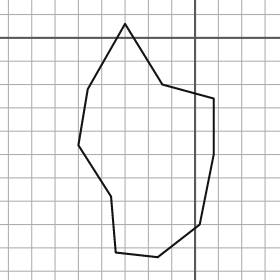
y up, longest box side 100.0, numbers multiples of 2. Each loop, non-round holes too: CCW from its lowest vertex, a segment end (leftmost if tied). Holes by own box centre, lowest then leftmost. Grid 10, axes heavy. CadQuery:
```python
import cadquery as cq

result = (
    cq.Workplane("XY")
    .moveTo(-16.0, -94.0)
    .lineTo(2.0, -80.0)
    .lineTo(8.0, -50.0)
    .lineTo(8.0, -26.0)
    .lineTo(-14.0, -20.0)
    .lineTo(-30.0, 6.0)
    .lineTo(-46.0, -22.0)
    .lineTo(-50.0, -46.0)
    .lineTo(-36.0, -68.0)
    .lineTo(-34.0, -92.0)
    .close()
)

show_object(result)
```